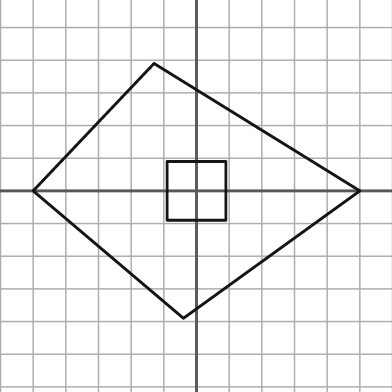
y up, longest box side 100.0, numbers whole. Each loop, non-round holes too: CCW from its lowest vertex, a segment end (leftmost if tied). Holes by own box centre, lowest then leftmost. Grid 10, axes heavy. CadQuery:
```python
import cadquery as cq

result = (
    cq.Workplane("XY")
    .moveTo(-4.0, -39.0)
    .lineTo(50.0, 0.0)
    .lineTo(-13.0, 39.0)
    .lineTo(-50.0, 0.0)
    .close()
    .moveTo(-9.0, -9.0)
    .lineTo(9.0, -9.0)
    .lineTo(9.0, 9.0)
    .lineTo(-9.0, 9.0)
    .close()
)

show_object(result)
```